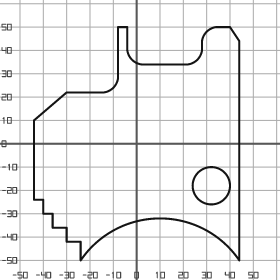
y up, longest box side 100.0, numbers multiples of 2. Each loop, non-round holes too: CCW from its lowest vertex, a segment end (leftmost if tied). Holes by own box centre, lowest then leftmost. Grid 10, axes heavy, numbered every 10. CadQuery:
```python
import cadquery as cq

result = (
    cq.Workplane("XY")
    .moveTo(-24.0, -50.0)
    .threePointArc((10.0, -32.0), (44.0, -50.0))
    .lineTo(44.0, 44.0)
    .lineTo(40.0, 50.0)
    .lineTo(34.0, 50.0)
    .threePointArc((30.0, 48.0), (28.0, 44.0))
    .lineTo(28.0, 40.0)
    .threePointArc((26.0, 36.0), (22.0, 34.0))
    .lineTo(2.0, 34.0)
    .threePointArc((-2.0, 36.0), (-4.0, 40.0))
    .lineTo(-4.0, 50.0)
    .lineTo(-8.0, 50.0)
    .lineTo(-8.0, 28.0)
    .threePointArc((-10.0, 24.0), (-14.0, 22.0))
    .lineTo(-30.0, 22.0)
    .lineTo(-44.0, 10.0)
    .lineTo(-44.0, -24.0)
    .lineTo(-40.0, -24.0)
    .lineTo(-40.0, -30.0)
    .lineTo(-36.0, -30.0)
    .lineTo(-36.0, -36.0)
    .lineTo(-30.0, -36.0)
    .lineTo(-30.0, -42.0)
    .lineTo(-24.0, -42.0)
    .close()
    .moveTo(32.0, -18.0)
    .circle(8.0)
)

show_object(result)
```